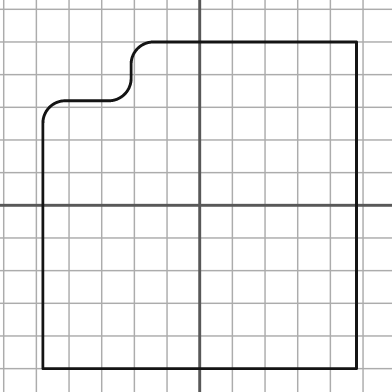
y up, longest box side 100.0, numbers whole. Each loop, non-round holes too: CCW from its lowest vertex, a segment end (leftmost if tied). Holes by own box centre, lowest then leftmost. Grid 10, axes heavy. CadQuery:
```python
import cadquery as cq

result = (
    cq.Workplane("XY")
    .moveTo(-48.0, -50.0)
    .lineTo(48.0, -50.0)
    .lineTo(48.0, 50.0)
    .lineTo(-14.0, 50.0)
    .threePointArc((-19.0, 48.0), (-21.0, 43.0))
    .lineTo(-21.0, 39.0)
    .threePointArc((-23.0, 34.0), (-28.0, 32.0))
    .lineTo(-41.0, 32.0)
    .threePointArc((-46.0, 30.0), (-48.0, 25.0))
    .close()
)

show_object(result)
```